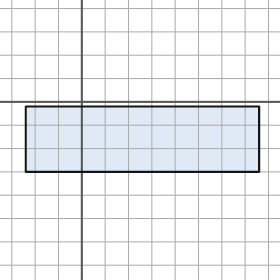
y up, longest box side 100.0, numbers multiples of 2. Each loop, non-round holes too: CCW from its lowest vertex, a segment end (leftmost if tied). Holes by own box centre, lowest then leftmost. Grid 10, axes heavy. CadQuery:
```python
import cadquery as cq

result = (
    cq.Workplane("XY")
    .moveTo(-24.0, -30.0)
    .lineTo(76.0, -30.0)
    .lineTo(76.0, -2.0)
    .lineTo(-24.0, -2.0)
    .close()
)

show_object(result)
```